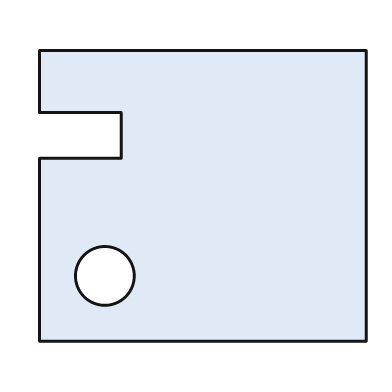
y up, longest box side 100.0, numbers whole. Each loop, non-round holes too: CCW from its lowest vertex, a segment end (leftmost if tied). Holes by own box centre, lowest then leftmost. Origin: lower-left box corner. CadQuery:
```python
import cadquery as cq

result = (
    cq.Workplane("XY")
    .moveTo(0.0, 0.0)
    .lineTo(100.0, 0.0)
    .lineTo(100.0, 89.0)
    .lineTo(0.0, 89.0)
    .lineTo(0.0, 70.0)
    .lineTo(25.0, 70.0)
    .lineTo(25.0, 56.0)
    .lineTo(0.0, 56.0)
    .close()
    .moveTo(20.0, 20.0)
    .circle(9.0)
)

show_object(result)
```